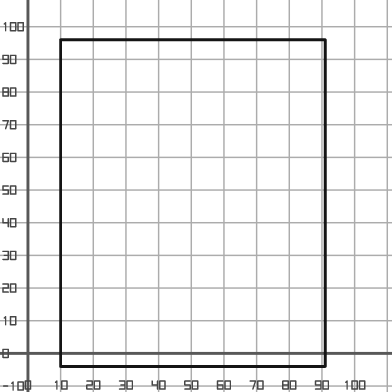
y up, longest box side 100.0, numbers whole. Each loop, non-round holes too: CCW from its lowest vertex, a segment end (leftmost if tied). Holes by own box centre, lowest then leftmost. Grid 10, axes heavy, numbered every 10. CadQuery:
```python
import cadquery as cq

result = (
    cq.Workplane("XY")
    .moveTo(10.0, -4.0)
    .lineTo(91.0, -4.0)
    .lineTo(91.0, 96.0)
    .lineTo(10.0, 96.0)
    .close()
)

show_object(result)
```